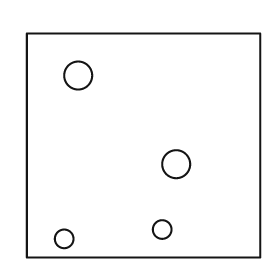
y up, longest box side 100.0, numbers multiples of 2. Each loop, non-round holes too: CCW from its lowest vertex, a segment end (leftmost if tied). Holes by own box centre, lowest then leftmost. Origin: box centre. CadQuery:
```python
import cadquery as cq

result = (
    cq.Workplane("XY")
    .moveTo(-50.0, -48.0)
    .lineTo(50.0, -48.0)
    .lineTo(50.0, 48.0)
    .lineTo(-50.0, 48.0)
    .close()
    .moveTo(-34.0, -40.0)
    .circle(4.0)
    .moveTo(8.0, -36.0)
    .circle(4.0)
    .moveTo(14.0, -8.0)
    .circle(6.0)
    .moveTo(-28.0, 30.0)
    .circle(6.0)
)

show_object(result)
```